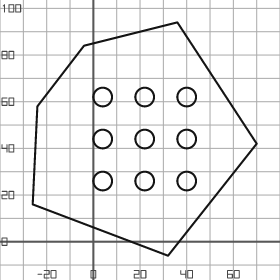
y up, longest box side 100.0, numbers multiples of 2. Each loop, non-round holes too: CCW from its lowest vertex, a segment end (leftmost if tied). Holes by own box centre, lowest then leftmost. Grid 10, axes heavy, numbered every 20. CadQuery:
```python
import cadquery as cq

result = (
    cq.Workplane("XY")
    .moveTo(32.0, -6.0)
    .lineTo(70.0, 42.0)
    .lineTo(36.0, 94.0)
    .lineTo(-4.0, 84.0)
    .lineTo(-24.0, 58.0)
    .lineTo(-26.0, 16.0)
    .close()
    .moveTo(4.0, 26.0)
    .circle(4.0)
    .moveTo(22.0, 26.0)
    .circle(4.0)
    .moveTo(40.0, 26.0)
    .circle(4.0)
    .moveTo(4.0, 44.0)
    .circle(4.0)
    .moveTo(22.0, 44.0)
    .circle(4.0)
    .moveTo(40.0, 44.0)
    .circle(4.0)
    .moveTo(4.0, 62.0)
    .circle(4.0)
    .moveTo(22.0, 62.0)
    .circle(4.0)
    .moveTo(40.0, 62.0)
    .circle(4.0)
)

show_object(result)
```